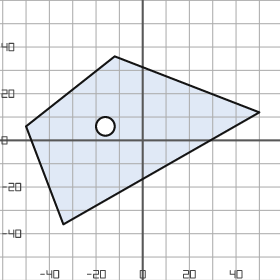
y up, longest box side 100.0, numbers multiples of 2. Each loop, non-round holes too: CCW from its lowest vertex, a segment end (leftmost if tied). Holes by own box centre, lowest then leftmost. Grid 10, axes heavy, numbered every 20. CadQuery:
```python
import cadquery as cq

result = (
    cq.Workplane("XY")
    .moveTo(-34.0, -36.0)
    .lineTo(50.0, 12.0)
    .lineTo(-12.0, 36.0)
    .lineTo(-50.0, 6.0)
    .close()
    .moveTo(-16.0, 6.0)
    .circle(4.0)
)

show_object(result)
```